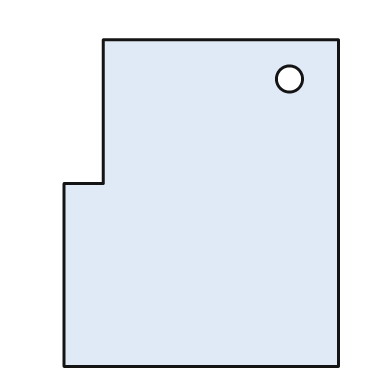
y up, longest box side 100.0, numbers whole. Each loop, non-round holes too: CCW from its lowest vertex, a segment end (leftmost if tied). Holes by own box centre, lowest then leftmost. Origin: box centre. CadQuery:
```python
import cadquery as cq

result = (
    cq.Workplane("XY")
    .moveTo(-42.0, -50.0)
    .lineTo(42.0, -50.0)
    .lineTo(42.0, 50.0)
    .lineTo(-30.0, 50.0)
    .lineTo(-30.0, 6.0)
    .lineTo(-42.0, 6.0)
    .close()
    .moveTo(27.0, 38.0)
    .circle(4.0)
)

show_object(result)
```